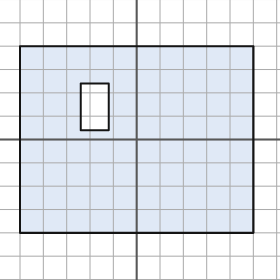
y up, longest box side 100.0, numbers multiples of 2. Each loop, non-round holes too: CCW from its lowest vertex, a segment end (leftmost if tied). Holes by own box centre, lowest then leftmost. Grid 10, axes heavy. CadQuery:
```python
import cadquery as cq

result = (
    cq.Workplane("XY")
    .moveTo(-50.0, -40.0)
    .lineTo(50.0, -40.0)
    .lineTo(50.0, 40.0)
    .lineTo(-50.0, 40.0)
    .close()
    .moveTo(-24.0, 4.0)
    .lineTo(-12.0, 4.0)
    .lineTo(-12.0, 24.0)
    .lineTo(-24.0, 24.0)
    .close()
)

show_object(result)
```